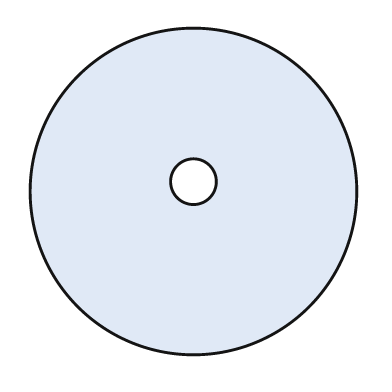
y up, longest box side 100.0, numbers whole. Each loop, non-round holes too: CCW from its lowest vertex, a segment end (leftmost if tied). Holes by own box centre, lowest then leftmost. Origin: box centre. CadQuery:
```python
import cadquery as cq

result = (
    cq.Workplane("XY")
    .moveTo(0.0, 0.0)
    .circle(50.0)
    .moveTo(0.0, 3.0)
    .circle(7.0)
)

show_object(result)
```